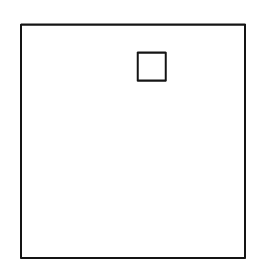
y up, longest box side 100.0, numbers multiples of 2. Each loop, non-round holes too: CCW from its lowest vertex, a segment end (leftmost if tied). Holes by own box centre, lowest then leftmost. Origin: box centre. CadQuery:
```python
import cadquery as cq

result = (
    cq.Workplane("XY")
    .moveTo(-48.0, -50.0)
    .lineTo(48.0, -50.0)
    .lineTo(48.0, 50.0)
    .lineTo(-48.0, 50.0)
    .close()
    .moveTo(2.0, 26.0)
    .lineTo(14.0, 26.0)
    .lineTo(14.0, 38.0)
    .lineTo(2.0, 38.0)
    .close()
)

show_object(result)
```